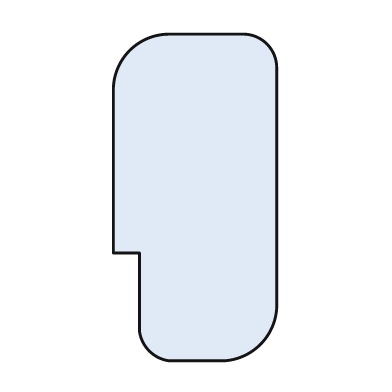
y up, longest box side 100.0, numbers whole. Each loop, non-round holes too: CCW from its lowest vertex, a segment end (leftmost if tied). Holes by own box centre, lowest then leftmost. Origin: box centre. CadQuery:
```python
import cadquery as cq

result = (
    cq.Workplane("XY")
    .moveTo(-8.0, -50.0)
    .lineTo(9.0, -50.0)
    .threePointArc((20.0, -45.0), (25.0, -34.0))
    .lineTo(25.0, 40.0)
    .threePointArc((22.0, 47.0), (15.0, 50.0))
    .lineTo(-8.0, 50.0)
    .threePointArc((-20.0, 45.0), (-25.0, 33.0))
    .lineTo(-25.0, -17.0)
    .lineTo(-17.0, -17.0)
    .lineTo(-17.0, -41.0)
    .threePointArc((-14.0, -47.0), (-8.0, -50.0))
    .close()
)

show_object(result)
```